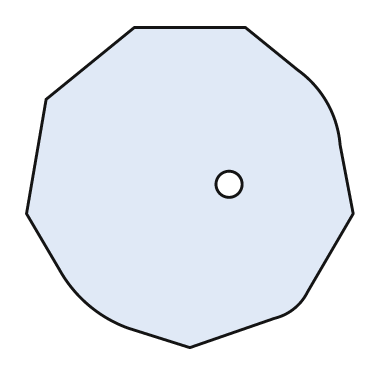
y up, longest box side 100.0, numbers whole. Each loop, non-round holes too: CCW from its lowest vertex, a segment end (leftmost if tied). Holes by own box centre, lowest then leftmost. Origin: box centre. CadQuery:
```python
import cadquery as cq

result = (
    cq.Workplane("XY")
    .moveTo(0.0, -49.0)
    .lineTo(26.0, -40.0)
    .threePointArc((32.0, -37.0), (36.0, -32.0))
    .lineTo(50.0, -8.0)
    .lineTo(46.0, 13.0)
    .threePointArc((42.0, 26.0), (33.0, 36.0))
    .lineTo(17.0, 49.0)
    .lineTo(-17.0, 49.0)
    .lineTo(-44.0, 27.0)
    .lineTo(-50.0, -8.0)
    .lineTo(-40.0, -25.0)
    .threePointArc((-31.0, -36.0), (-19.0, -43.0))
    .close()
    .moveTo(12.0, 1.0)
    .circle(4.0)
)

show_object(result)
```